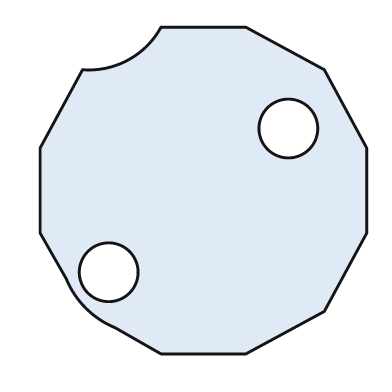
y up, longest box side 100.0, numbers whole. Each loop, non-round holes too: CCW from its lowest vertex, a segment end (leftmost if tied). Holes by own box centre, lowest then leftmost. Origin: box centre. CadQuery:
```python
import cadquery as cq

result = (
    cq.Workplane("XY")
    .moveTo(-13.0, -50.0)
    .lineTo(13.0, -50.0)
    .lineTo(37.0, -37.0)
    .lineTo(50.0, -13.0)
    .lineTo(50.0, 13.0)
    .lineTo(37.0, 37.0)
    .lineTo(13.0, 50.0)
    .lineTo(-13.0, 50.0)
    .threePointArc((-23.0, 40.0), (-37.0, 37.0))
    .lineTo(-50.0, 13.0)
    .lineTo(-50.0, -13.0)
    .lineTo(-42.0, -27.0)
    .threePointArc((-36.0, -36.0), (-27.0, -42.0))
    .close()
    .moveTo(-29.0, -25.0)
    .circle(9.0)
    .moveTo(26.0, 19.0)
    .circle(9.0)
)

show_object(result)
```